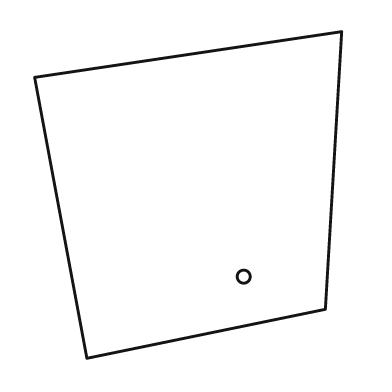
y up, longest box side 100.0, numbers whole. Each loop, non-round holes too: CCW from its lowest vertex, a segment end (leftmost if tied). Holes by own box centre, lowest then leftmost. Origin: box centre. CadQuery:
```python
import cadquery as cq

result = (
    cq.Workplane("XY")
    .moveTo(-31.0, -50.0)
    .lineTo(42.0, -35.0)
    .lineTo(47.0, 50.0)
    .lineTo(-47.0, 36.0)
    .close()
    .moveTo(17.0, -25.0)
    .circle(2.0)
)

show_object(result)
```